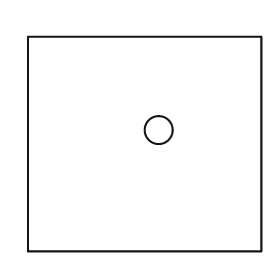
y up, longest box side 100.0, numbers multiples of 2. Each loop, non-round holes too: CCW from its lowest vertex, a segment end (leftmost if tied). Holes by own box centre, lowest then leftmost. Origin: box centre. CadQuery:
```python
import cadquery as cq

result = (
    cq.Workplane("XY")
    .moveTo(-50.0, -46.0)
    .lineTo(50.0, -46.0)
    .lineTo(50.0, 46.0)
    .lineTo(-50.0, 46.0)
    .close()
    .moveTo(6.0, 6.0)
    .circle(6.0)
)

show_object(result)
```